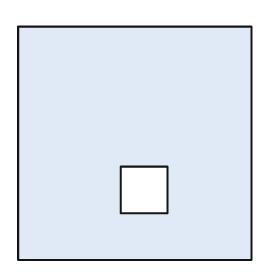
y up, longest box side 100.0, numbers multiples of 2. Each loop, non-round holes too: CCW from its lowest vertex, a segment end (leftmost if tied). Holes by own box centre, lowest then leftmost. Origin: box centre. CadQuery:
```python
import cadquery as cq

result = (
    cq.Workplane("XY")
    .moveTo(-50.0, -50.0)
    .lineTo(50.0, -50.0)
    .lineTo(50.0, 50.0)
    .lineTo(-50.0, 50.0)
    .close()
    .moveTo(-6.0, -30.0)
    .lineTo(14.0, -30.0)
    .lineTo(14.0, -10.0)
    .lineTo(-6.0, -10.0)
    .close()
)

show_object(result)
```